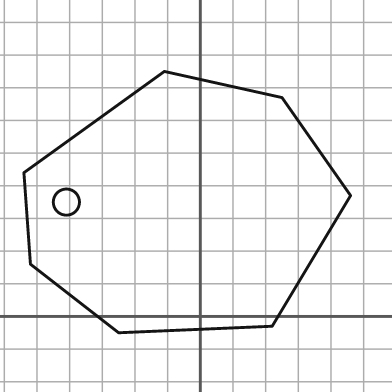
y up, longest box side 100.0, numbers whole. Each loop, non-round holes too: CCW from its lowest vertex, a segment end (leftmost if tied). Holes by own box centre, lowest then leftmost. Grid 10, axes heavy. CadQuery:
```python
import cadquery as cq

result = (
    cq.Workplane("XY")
    .moveTo(-25.0, -5.0)
    .lineTo(22.0, -3.0)
    .lineTo(46.0, 37.0)
    .lineTo(25.0, 67.0)
    .lineTo(-11.0, 75.0)
    .lineTo(-54.0, 44.0)
    .lineTo(-52.0, 16.0)
    .close()
    .moveTo(-41.0, 35.0)
    .circle(4.0)
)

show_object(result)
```